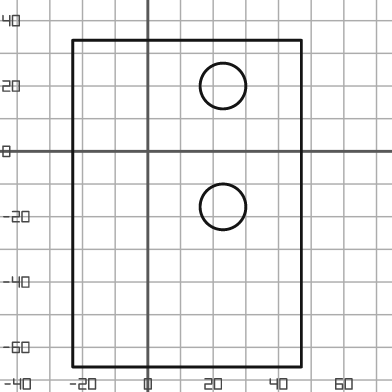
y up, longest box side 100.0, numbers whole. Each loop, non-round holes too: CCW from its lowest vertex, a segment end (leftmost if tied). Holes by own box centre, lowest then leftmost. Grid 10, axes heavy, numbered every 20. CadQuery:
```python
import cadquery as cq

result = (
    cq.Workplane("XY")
    .moveTo(-23.0, -66.0)
    .lineTo(47.0, -66.0)
    .lineTo(47.0, 34.0)
    .lineTo(-23.0, 34.0)
    .close()
    .moveTo(23.0, -17.0)
    .circle(7.0)
    .moveTo(23.0, 20.0)
    .circle(7.0)
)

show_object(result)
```